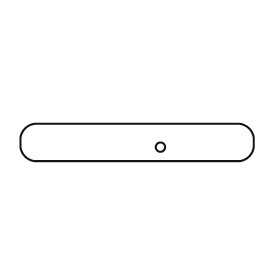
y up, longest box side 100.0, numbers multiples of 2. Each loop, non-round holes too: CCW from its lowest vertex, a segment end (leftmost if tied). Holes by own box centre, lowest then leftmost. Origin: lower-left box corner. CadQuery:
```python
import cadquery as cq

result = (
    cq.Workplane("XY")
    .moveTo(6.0, 0.0)
    .lineTo(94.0, 0.0)
    .threePointArc((98.0, 2.0), (100.0, 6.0))
    .lineTo(100.0, 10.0)
    .threePointArc((98.0, 14.0), (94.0, 16.0))
    .lineTo(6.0, 16.0)
    .threePointArc((2.0, 14.0), (0.0, 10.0))
    .lineTo(0.0, 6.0)
    .threePointArc((2.0, 2.0), (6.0, 0.0))
    .close()
    .moveTo(60.0, 6.0)
    .circle(2.0)
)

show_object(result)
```